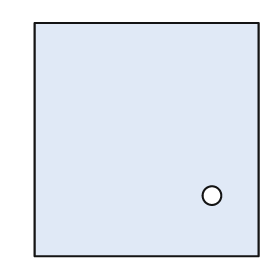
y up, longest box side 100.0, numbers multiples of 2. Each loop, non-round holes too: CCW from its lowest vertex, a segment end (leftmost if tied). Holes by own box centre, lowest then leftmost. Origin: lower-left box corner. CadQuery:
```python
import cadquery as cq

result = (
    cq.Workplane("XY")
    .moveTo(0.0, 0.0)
    .lineTo(96.0, 0.0)
    .lineTo(96.0, 100.0)
    .lineTo(0.0, 100.0)
    .close()
    .moveTo(76.0, 26.0)
    .circle(4.0)
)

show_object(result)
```